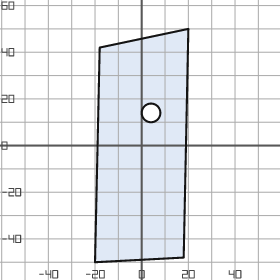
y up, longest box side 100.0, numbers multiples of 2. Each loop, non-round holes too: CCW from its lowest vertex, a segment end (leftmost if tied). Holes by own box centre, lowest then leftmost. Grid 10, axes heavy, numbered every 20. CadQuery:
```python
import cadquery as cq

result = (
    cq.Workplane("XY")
    .moveTo(-20.0, -50.0)
    .lineTo(18.0, -48.0)
    .lineTo(20.0, 50.0)
    .lineTo(-18.0, 42.0)
    .close()
    .moveTo(4.0, 14.0)
    .circle(4.0)
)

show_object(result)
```